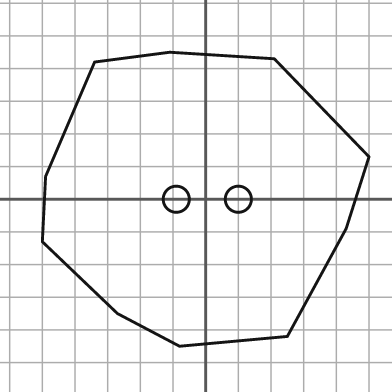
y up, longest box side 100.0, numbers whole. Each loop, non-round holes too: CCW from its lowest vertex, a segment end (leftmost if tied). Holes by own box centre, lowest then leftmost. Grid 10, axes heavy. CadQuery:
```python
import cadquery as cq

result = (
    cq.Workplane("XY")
    .moveTo(-8.0, -45.0)
    .lineTo(25.0, -42.0)
    .lineTo(43.0, -9.0)
    .lineTo(50.0, 13.0)
    .lineTo(21.0, 43.0)
    .lineTo(-11.0, 45.0)
    .lineTo(-34.0, 42.0)
    .lineTo(-49.0, 7.0)
    .lineTo(-50.0, -13.0)
    .lineTo(-27.0, -35.0)
    .close()
    .moveTo(-9.0, 0.0)
    .circle(4.0)
    .moveTo(10.0, 0.0)
    .circle(4.0)
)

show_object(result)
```